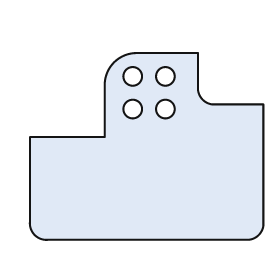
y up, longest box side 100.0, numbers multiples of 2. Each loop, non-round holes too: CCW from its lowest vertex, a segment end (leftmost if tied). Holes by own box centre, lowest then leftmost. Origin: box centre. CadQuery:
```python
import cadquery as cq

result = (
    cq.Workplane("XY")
    .moveTo(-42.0, -40.0)
    .lineTo(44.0, -40.0)
    .threePointArc((48.0, -38.0), (50.0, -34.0))
    .lineTo(50.0, 18.0)
    .lineTo(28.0, 18.0)
    .threePointArc((24.0, 20.0), (22.0, 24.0))
    .lineTo(22.0, 40.0)
    .lineTo(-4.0, 40.0)
    .threePointArc((-14.0, 36.0), (-18.0, 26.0))
    .lineTo(-18.0, 4.0)
    .lineTo(-50.0, 4.0)
    .lineTo(-50.0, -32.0)
    .threePointArc((-48.0, -38.0), (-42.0, -40.0))
    .close()
    .moveTo(-6.0, 16.0)
    .circle(4.0)
    .moveTo(8.0, 16.0)
    .circle(4.0)
    .moveTo(-6.0, 30.0)
    .circle(4.0)
    .moveTo(8.0, 30.0)
    .circle(4.0)
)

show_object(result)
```